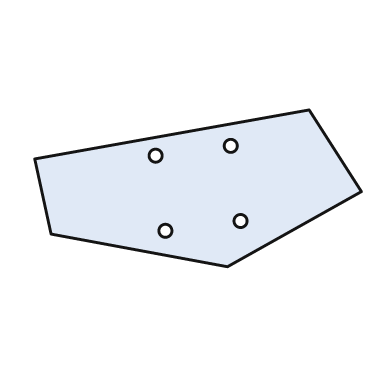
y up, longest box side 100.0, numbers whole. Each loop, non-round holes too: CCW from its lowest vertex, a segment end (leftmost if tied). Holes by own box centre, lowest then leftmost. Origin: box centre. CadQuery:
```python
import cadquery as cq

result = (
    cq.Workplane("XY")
    .moveTo(9.0, -24.0)
    .lineTo(50.0, -1.0)
    .lineTo(34.0, 24.0)
    .lineTo(-50.0, 9.0)
    .lineTo(-45.0, -14.0)
    .close()
    .moveTo(-10.0, -13.0)
    .circle(2.0)
    .moveTo(13.0, -10.0)
    .circle(2.0)
    .moveTo(-13.0, 10.0)
    .circle(2.0)
    .moveTo(10.0, 13.0)
    .circle(2.0)
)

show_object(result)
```